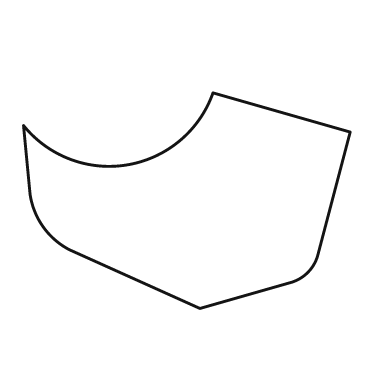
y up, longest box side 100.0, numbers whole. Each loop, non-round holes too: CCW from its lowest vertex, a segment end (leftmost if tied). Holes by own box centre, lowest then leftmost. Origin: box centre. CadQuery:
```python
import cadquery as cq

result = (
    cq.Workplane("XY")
    .moveTo(4.0, -33.0)
    .lineTo(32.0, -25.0)
    .threePointArc((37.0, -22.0), (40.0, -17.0))
    .lineTo(50.0, 21.0)
    .lineTo(8.0, 33.0)
    .threePointArc((-18.0, 11.0), (-50.0, 23.0))
    .lineTo(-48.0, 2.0)
    .threePointArc((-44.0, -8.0), (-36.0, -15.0))
    .close()
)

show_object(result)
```